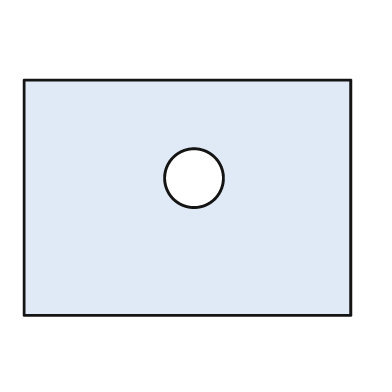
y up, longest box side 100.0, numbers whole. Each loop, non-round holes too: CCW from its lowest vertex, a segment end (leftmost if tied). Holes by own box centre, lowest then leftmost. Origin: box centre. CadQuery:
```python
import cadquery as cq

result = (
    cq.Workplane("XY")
    .moveTo(-50.0, -36.0)
    .lineTo(50.0, -36.0)
    .lineTo(50.0, 36.0)
    .lineTo(-50.0, 36.0)
    .close()
    .moveTo(2.0, 6.0)
    .circle(9.0)
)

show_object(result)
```